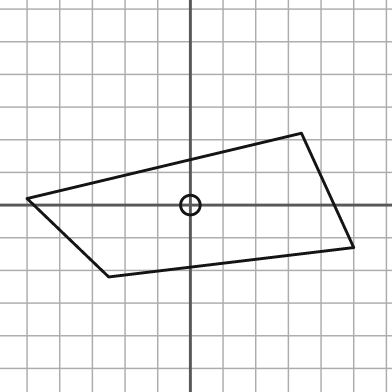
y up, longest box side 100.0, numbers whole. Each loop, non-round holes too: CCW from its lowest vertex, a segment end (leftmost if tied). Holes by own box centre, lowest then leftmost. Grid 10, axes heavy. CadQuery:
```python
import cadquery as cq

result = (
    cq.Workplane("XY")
    .moveTo(-25.0, -22.0)
    .lineTo(50.0, -13.0)
    .lineTo(34.0, 22.0)
    .lineTo(-50.0, 2.0)
    .close()
    .moveTo(0.0, 0.0)
    .circle(3.0)
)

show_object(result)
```